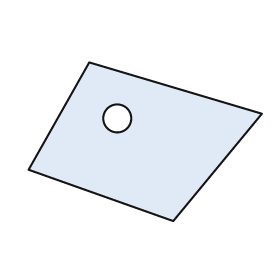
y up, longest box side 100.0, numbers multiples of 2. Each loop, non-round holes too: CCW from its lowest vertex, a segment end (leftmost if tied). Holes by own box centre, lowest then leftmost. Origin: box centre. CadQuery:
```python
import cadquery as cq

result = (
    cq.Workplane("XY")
    .moveTo(12.0, -34.0)
    .lineTo(50.0, 12.0)
    .lineTo(-24.0, 34.0)
    .lineTo(-50.0, -12.0)
    .close()
    .moveTo(-12.0, 10.0)
    .circle(6.0)
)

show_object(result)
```